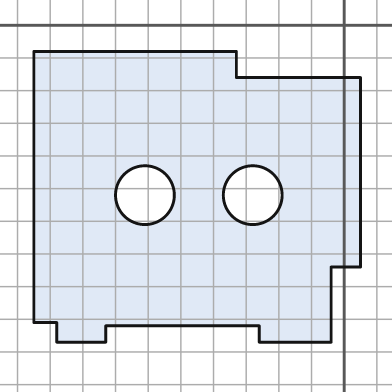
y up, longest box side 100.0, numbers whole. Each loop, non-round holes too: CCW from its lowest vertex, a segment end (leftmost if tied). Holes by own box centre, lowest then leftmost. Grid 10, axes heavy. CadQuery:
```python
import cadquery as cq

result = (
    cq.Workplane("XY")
    .moveTo(-88.0, -97.0)
    .lineTo(-73.0, -97.0)
    .lineTo(-73.0, -92.0)
    .lineTo(-26.0, -92.0)
    .lineTo(-26.0, -97.0)
    .lineTo(-4.0, -97.0)
    .lineTo(-4.0, -74.0)
    .lineTo(5.0, -74.0)
    .lineTo(5.0, -16.0)
    .lineTo(-33.0, -16.0)
    .lineTo(-33.0, -8.0)
    .lineTo(-95.0, -8.0)
    .lineTo(-95.0, -91.0)
    .lineTo(-88.0, -91.0)
    .close()
    .moveTo(-61.0, -52.0)
    .circle(9.0)
    .moveTo(-28.0, -52.0)
    .circle(9.0)
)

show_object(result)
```